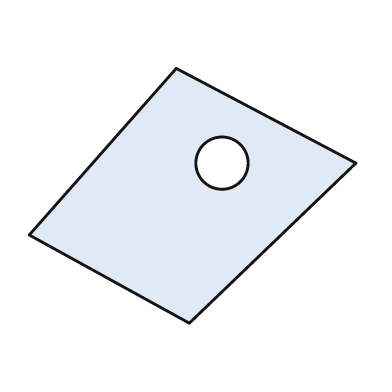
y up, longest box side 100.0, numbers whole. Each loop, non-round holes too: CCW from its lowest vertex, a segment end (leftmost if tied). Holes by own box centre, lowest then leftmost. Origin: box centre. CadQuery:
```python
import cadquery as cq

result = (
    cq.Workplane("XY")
    .moveTo(-1.0, -39.0)
    .lineTo(50.0, 10.0)
    .lineTo(-5.0, 39.0)
    .lineTo(-50.0, -12.0)
    .close()
    .moveTo(9.0, 10.0)
    .circle(8.0)
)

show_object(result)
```